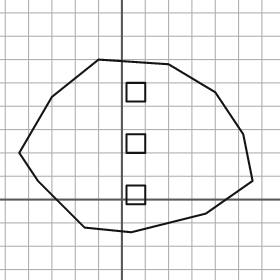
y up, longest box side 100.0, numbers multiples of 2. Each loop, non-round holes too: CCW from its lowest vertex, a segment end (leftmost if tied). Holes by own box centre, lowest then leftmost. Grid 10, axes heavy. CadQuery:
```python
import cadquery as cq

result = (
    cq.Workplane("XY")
    .moveTo(4.0, -14.0)
    .lineTo(36.0, -6.0)
    .lineTo(56.0, 8.0)
    .lineTo(52.0, 28.0)
    .lineTo(40.0, 46.0)
    .lineTo(20.0, 58.0)
    .lineTo(-10.0, 60.0)
    .lineTo(-30.0, 44.0)
    .lineTo(-44.0, 20.0)
    .lineTo(-36.0, 8.0)
    .lineTo(-16.0, -12.0)
    .close()
    .moveTo(2.0, -2.0)
    .lineTo(10.0, -2.0)
    .lineTo(10.0, 6.0)
    .lineTo(2.0, 6.0)
    .close()
    .moveTo(2.0, 20.0)
    .lineTo(10.0, 20.0)
    .lineTo(10.0, 28.0)
    .lineTo(2.0, 28.0)
    .close()
    .moveTo(2.0, 42.0)
    .lineTo(10.0, 42.0)
    .lineTo(10.0, 50.0)
    .lineTo(2.0, 50.0)
    .close()
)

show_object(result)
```